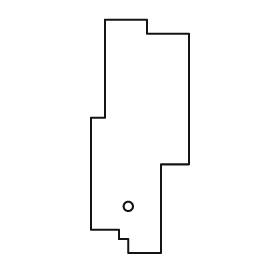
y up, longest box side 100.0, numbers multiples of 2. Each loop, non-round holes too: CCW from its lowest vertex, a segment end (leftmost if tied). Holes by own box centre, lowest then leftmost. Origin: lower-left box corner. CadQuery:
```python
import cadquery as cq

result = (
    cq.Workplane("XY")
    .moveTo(16.0, 0.0)
    .lineTo(30.0, 0.0)
    .lineTo(30.0, 38.0)
    .lineTo(42.0, 38.0)
    .lineTo(42.0, 94.0)
    .lineTo(24.0, 94.0)
    .lineTo(24.0, 100.0)
    .lineTo(6.0, 100.0)
    .lineTo(6.0, 58.0)
    .lineTo(0.0, 58.0)
    .lineTo(0.0, 10.0)
    .lineTo(12.0, 10.0)
    .lineTo(12.0, 6.0)
    .lineTo(16.0, 6.0)
    .close()
    .moveTo(16.0, 20.0)
    .circle(2.0)
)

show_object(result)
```